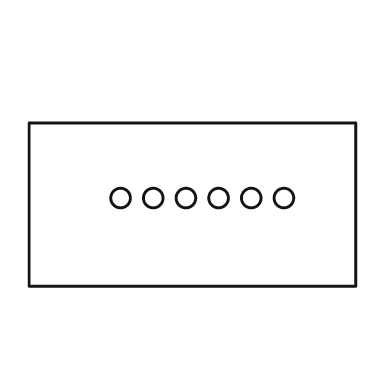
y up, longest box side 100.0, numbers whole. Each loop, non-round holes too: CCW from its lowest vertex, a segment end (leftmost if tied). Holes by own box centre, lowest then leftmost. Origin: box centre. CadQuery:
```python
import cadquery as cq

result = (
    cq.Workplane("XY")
    .moveTo(-50.0, -25.0)
    .lineTo(50.0, -25.0)
    .lineTo(50.0, 25.0)
    .lineTo(-50.0, 25.0)
    .close()
    .moveTo(-22.0, 2.0)
    .circle(3.0)
    .moveTo(-12.0, 2.0)
    .circle(3.0)
    .moveTo(-2.0, 2.0)
    .circle(3.0)
    .moveTo(8.0, 2.0)
    .circle(3.0)
    .moveTo(18.0, 2.0)
    .circle(3.0)
    .moveTo(28.0, 2.0)
    .circle(3.0)
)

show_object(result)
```